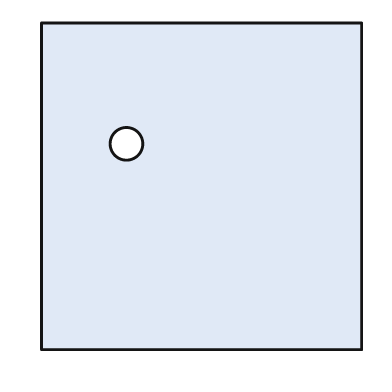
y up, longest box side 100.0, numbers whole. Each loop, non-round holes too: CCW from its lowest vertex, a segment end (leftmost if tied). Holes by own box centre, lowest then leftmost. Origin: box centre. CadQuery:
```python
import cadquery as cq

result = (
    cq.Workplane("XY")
    .moveTo(-49.0, -50.0)
    .lineTo(49.0, -50.0)
    .lineTo(49.0, 50.0)
    .lineTo(-49.0, 50.0)
    .close()
    .moveTo(-23.0, 13.0)
    .circle(5.0)
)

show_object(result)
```